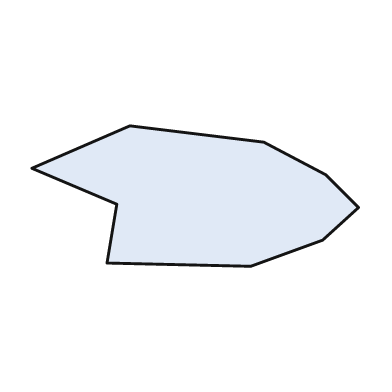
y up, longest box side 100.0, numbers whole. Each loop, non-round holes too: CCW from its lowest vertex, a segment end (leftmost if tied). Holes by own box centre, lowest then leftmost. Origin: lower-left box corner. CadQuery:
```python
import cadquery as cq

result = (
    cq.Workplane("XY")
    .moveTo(67.0, 0.0)
    .lineTo(89.0, 8.0)
    .lineTo(100.0, 18.0)
    .lineTo(90.0, 28.0)
    .lineTo(71.0, 38.0)
    .lineTo(30.0, 43.0)
    .lineTo(0.0, 30.0)
    .lineTo(26.0, 19.0)
    .lineTo(23.0, 1.0)
    .close()
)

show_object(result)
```